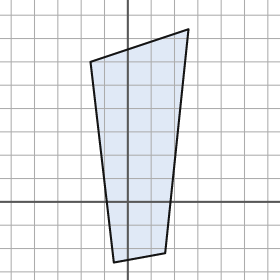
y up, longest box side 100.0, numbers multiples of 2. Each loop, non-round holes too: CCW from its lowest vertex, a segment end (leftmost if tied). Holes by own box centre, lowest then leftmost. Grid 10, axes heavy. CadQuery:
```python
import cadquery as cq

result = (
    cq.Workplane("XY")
    .moveTo(-6.0, -26.0)
    .lineTo(16.0, -22.0)
    .lineTo(26.0, 74.0)
    .lineTo(-16.0, 60.0)
    .close()
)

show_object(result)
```